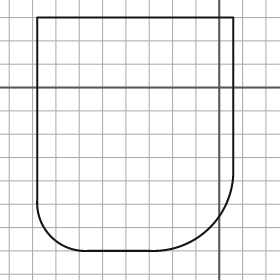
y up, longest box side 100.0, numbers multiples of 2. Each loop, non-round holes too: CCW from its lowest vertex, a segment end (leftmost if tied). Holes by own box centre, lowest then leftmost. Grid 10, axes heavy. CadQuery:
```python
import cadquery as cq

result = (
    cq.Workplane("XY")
    .moveTo(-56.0, -70.0)
    .lineTo(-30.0, -70.0)
    .threePointArc((-4.0, -60.0), (6.0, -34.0))
    .lineTo(6.0, 30.0)
    .lineTo(-78.0, 30.0)
    .lineTo(-78.0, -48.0)
    .threePointArc((-72.0, -64.0), (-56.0, -70.0))
    .close()
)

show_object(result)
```